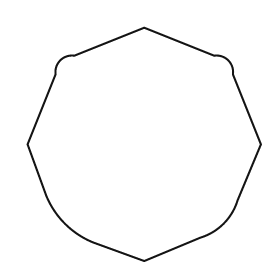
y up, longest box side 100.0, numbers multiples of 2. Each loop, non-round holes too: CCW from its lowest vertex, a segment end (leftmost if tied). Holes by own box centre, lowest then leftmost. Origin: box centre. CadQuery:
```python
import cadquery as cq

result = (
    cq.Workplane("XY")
    .moveTo(0.0, -50.0)
    .lineTo(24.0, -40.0)
    .threePointArc((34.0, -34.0), (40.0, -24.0))
    .lineTo(50.0, 0.0)
    .lineTo(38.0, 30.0)
    .threePointArc((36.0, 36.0), (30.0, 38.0))
    .lineTo(0.0, 50.0)
    .lineTo(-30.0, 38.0)
    .threePointArc((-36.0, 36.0), (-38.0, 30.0))
    .lineTo(-50.0, 0.0)
    .lineTo(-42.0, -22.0)
    .threePointArc((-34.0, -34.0), (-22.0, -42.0))
    .close()
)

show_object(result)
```